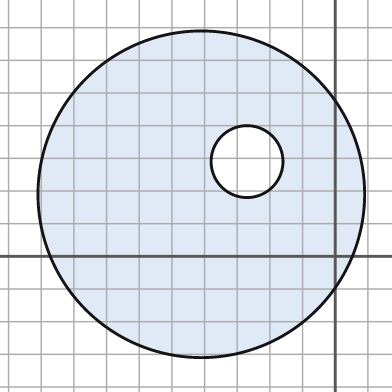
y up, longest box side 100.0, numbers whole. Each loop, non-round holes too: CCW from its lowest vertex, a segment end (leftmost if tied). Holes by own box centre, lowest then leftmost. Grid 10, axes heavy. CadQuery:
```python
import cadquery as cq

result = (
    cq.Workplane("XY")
    .moveTo(-41.0, 19.0)
    .circle(50.0)
    .moveTo(-27.0, 29.0)
    .circle(11.0)
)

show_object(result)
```